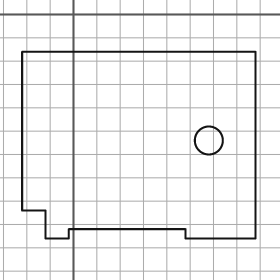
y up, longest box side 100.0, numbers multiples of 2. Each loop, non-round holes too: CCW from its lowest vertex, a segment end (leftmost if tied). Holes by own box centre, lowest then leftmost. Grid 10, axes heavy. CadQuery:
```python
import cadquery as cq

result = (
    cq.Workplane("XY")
    .moveTo(-12.0, -96.0)
    .lineTo(-2.0, -96.0)
    .lineTo(-2.0, -92.0)
    .lineTo(48.0, -92.0)
    .lineTo(48.0, -96.0)
    .lineTo(78.0, -96.0)
    .lineTo(78.0, -16.0)
    .lineTo(-22.0, -16.0)
    .lineTo(-22.0, -84.0)
    .lineTo(-12.0, -84.0)
    .close()
    .moveTo(58.0, -54.0)
    .circle(6.0)
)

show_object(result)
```